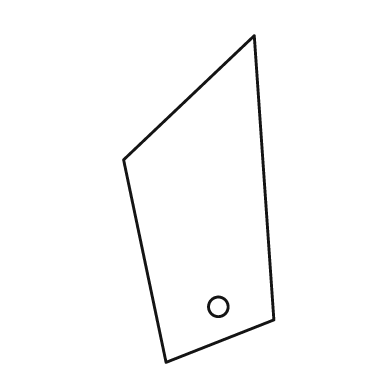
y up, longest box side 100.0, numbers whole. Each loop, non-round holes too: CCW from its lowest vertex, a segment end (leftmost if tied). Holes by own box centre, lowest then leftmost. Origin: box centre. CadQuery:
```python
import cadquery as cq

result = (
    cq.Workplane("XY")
    .moveTo(-10.0, -50.0)
    .lineTo(23.0, -37.0)
    .lineTo(17.0, 50.0)
    .lineTo(-23.0, 12.0)
    .close()
    .moveTo(6.0, -33.0)
    .circle(3.0)
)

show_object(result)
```